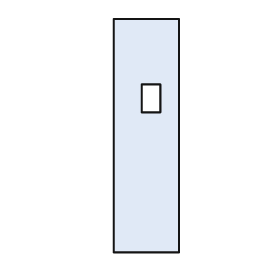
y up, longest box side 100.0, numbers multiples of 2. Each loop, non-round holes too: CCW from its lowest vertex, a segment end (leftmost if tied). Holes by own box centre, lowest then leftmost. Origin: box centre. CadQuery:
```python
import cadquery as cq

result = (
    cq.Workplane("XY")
    .moveTo(-14.0, -50.0)
    .lineTo(14.0, -50.0)
    .lineTo(14.0, 50.0)
    .lineTo(-14.0, 50.0)
    .close()
    .moveTo(-2.0, 10.0)
    .lineTo(6.0, 10.0)
    .lineTo(6.0, 22.0)
    .lineTo(-2.0, 22.0)
    .close()
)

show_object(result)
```